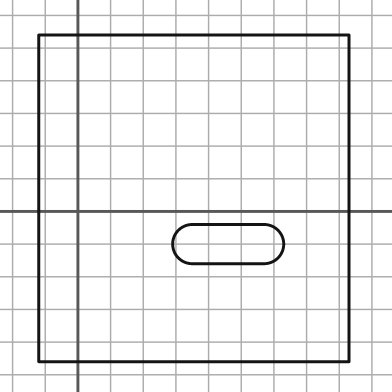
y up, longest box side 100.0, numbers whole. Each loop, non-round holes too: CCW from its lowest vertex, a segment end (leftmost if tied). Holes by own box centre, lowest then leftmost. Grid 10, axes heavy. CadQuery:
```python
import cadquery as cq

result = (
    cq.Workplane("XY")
    .moveTo(-12.0, -46.0)
    .lineTo(83.0, -46.0)
    .lineTo(83.0, 54.0)
    .lineTo(-12.0, 54.0)
    .close()
    .moveTo(35.0, -16.0)
    .lineTo(57.0, -16.0)
    .threePointArc((63.0, -10.0), (57.0, -4.0))
    .lineTo(35.0, -4.0)
    .threePointArc((29.0, -10.0), (35.0, -16.0))
    .close()
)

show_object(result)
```